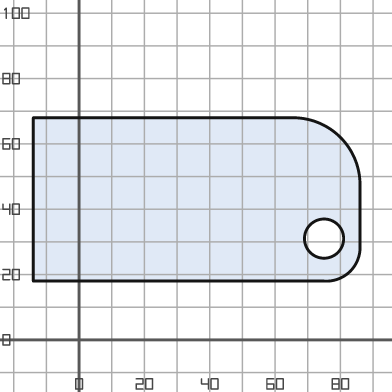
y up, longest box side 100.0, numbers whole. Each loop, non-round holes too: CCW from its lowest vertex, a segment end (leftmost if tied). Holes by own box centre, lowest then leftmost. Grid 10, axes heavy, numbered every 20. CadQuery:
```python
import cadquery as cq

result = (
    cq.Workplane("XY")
    .moveTo(-14.0, 18.0)
    .lineTo(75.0, 18.0)
    .threePointArc((83.0, 21.0), (86.0, 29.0))
    .lineTo(86.0, 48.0)
    .threePointArc((80.0, 62.0), (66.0, 68.0))
    .lineTo(-14.0, 68.0)
    .close()
    .moveTo(75.0, 31.0)
    .circle(6.0)
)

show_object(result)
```